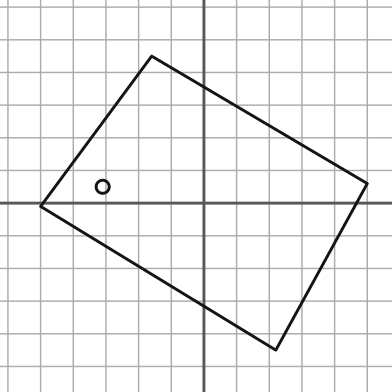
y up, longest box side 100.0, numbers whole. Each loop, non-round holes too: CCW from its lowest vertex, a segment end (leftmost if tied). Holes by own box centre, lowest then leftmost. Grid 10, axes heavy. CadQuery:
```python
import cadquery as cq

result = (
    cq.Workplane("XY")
    .moveTo(22.0, -45.0)
    .lineTo(50.0, 6.0)
    .lineTo(-16.0, 45.0)
    .lineTo(-50.0, -1.0)
    .close()
    .moveTo(-31.0, 5.0)
    .circle(2.0)
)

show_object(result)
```